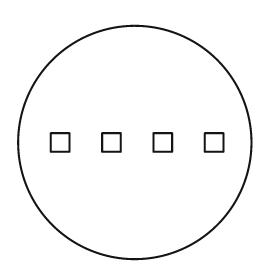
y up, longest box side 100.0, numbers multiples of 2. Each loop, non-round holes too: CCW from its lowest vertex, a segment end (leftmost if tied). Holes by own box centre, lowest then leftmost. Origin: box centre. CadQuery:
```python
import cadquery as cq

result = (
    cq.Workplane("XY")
    .moveTo(0.0, 0.0)
    .circle(50.0)
    .moveTo(-36.0, -4.0)
    .lineTo(-28.0, -4.0)
    .lineTo(-28.0, 4.0)
    .lineTo(-36.0, 4.0)
    .close()
    .moveTo(-14.0, -4.0)
    .lineTo(-6.0, -4.0)
    .lineTo(-6.0, 4.0)
    .lineTo(-14.0, 4.0)
    .close()
    .moveTo(8.0, -4.0)
    .lineTo(16.0, -4.0)
    .lineTo(16.0, 4.0)
    .lineTo(8.0, 4.0)
    .close()
    .moveTo(30.0, -4.0)
    .lineTo(38.0, -4.0)
    .lineTo(38.0, 4.0)
    .lineTo(30.0, 4.0)
    .close()
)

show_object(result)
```